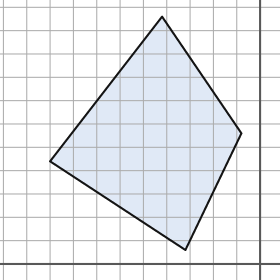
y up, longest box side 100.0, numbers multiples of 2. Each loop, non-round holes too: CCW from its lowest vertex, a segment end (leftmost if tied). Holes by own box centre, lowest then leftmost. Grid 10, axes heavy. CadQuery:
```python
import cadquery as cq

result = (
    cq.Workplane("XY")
    .moveTo(-32.0, 6.0)
    .lineTo(-8.0, 56.0)
    .lineTo(-42.0, 106.0)
    .lineTo(-90.0, 44.0)
    .close()
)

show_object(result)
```